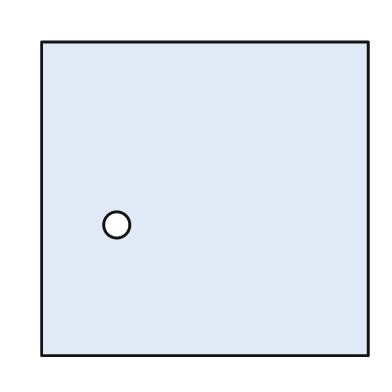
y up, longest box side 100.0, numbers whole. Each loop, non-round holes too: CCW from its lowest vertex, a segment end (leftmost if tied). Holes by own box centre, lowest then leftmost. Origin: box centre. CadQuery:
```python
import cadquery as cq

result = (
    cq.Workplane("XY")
    .moveTo(-50.0, -48.0)
    .lineTo(50.0, -48.0)
    .lineTo(50.0, 48.0)
    .lineTo(-50.0, 48.0)
    .close()
    .moveTo(-27.0, -8.0)
    .circle(4.0)
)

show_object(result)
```